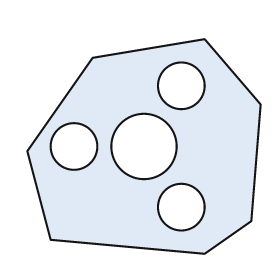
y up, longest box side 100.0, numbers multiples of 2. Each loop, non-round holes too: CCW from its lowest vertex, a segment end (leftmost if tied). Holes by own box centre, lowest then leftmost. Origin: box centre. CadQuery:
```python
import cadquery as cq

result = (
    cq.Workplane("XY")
    .moveTo(26.0, -46.0)
    .lineTo(46.0, -32.0)
    .lineTo(50.0, 18.0)
    .lineTo(26.0, 46.0)
    .lineTo(-22.0, 38.0)
    .lineTo(-50.0, -2.0)
    .lineTo(-40.0, -40.0)
    .close()
    .moveTo(16.0, -26.0)
    .circle(10.0)
    .moveTo(-30.0, 0.0)
    .circle(10.0)
    .moveTo(0.0, 0.0)
    .circle(14.0)
    .moveTo(16.0, 26.0)
    .circle(10.0)
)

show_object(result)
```